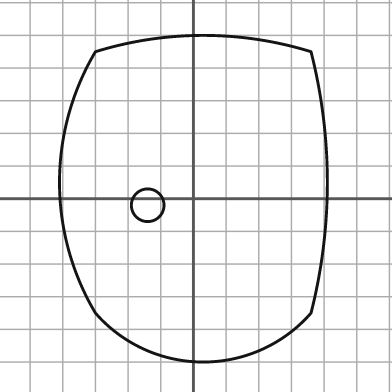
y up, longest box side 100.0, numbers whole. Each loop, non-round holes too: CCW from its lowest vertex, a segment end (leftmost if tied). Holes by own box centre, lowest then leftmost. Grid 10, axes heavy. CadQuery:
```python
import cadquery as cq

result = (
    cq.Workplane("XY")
    .moveTo(-30.0, -35.0)
    .threePointArc((3.0, -50.0), (36.0, -35.0))
    .threePointArc((41.0, 5.0), (36.0, 45.0))
    .threePointArc((3.0, 50.0), (-30.0, 45.0))
    .threePointArc((-41.0, 5.0), (-30.0, -35.0))
    .close()
    .moveTo(-14.0, -2.0)
    .circle(5.0)
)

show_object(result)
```